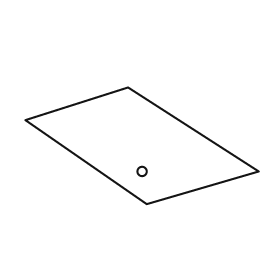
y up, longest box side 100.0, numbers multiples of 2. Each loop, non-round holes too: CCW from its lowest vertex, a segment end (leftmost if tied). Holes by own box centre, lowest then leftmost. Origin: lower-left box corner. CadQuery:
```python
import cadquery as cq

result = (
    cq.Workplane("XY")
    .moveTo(52.0, 0.0)
    .lineTo(100.0, 14.0)
    .lineTo(44.0, 50.0)
    .lineTo(0.0, 36.0)
    .close()
    .moveTo(50.0, 14.0)
    .circle(2.0)
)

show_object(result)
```